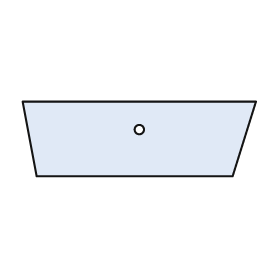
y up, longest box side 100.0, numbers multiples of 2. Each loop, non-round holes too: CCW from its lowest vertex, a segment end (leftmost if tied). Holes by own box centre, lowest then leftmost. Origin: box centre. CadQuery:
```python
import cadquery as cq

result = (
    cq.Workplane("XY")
    .moveTo(-44.0, -16.0)
    .lineTo(40.0, -16.0)
    .lineTo(50.0, 16.0)
    .lineTo(-50.0, 16.0)
    .close()
    .moveTo(0.0, 4.0)
    .circle(2.0)
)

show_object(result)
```